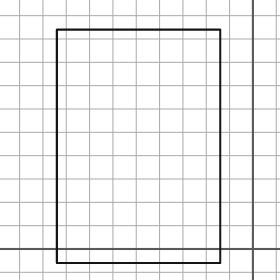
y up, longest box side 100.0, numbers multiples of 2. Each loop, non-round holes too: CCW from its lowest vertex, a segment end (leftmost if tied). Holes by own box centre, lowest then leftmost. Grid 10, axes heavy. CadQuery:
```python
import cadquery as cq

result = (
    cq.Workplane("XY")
    .moveTo(-84.0, -6.0)
    .lineTo(-14.0, -6.0)
    .lineTo(-14.0, 94.0)
    .lineTo(-84.0, 94.0)
    .close()
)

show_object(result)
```